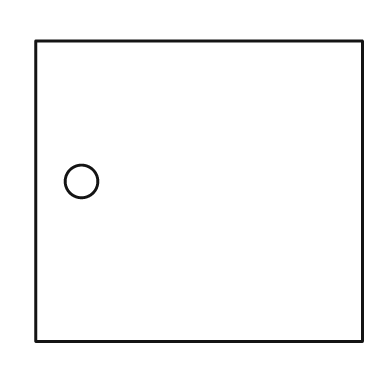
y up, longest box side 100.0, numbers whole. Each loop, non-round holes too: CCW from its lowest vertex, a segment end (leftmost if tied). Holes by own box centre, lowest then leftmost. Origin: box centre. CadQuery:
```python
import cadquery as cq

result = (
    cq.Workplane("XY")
    .moveTo(-50.0, -46.0)
    .lineTo(50.0, -46.0)
    .lineTo(50.0, 46.0)
    .lineTo(-50.0, 46.0)
    .close()
    .moveTo(-36.0, 3.0)
    .circle(5.0)
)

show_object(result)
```